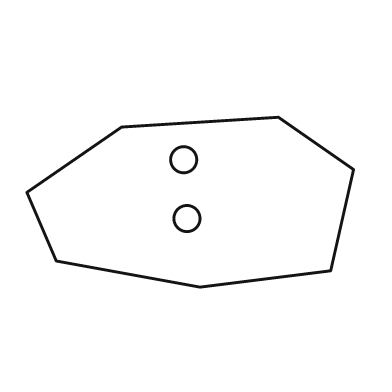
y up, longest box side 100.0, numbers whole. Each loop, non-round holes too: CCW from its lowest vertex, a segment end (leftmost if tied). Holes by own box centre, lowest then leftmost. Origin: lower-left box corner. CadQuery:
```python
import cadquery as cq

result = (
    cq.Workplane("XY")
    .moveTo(53.0, 0.0)
    .lineTo(93.0, 5.0)
    .lineTo(100.0, 36.0)
    .lineTo(77.0, 52.0)
    .lineTo(29.0, 49.0)
    .lineTo(0.0, 29.0)
    .lineTo(9.0, 8.0)
    .close()
    .moveTo(49.0, 21.0)
    .circle(4.0)
    .moveTo(48.0, 39.0)
    .circle(4.0)
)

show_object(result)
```